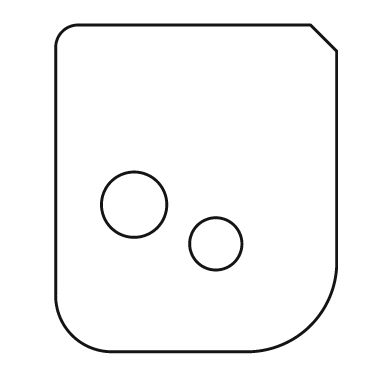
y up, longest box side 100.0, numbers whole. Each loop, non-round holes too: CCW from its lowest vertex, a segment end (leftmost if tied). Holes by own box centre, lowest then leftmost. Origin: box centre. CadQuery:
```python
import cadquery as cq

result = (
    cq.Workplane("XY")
    .moveTo(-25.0, -50.0)
    .lineTo(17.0, -50.0)
    .threePointArc((35.0, -42.0), (43.0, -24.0))
    .lineTo(43.0, 42.0)
    .lineTo(35.0, 50.0)
    .lineTo(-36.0, 50.0)
    .threePointArc((-41.0, 48.0), (-43.0, 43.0))
    .lineTo(-43.0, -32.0)
    .threePointArc((-38.0, -45.0), (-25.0, -50.0))
    .close()
    .moveTo(6.0, -17.0)
    .circle(8.0)
    .moveTo(-19.0, -5.0)
    .circle(10.0)
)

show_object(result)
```